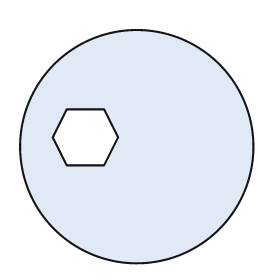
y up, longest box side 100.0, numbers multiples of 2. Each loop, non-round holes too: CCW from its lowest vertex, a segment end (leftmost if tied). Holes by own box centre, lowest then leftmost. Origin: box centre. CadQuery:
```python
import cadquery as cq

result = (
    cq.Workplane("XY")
    .moveTo(0.0, 0.0)
    .circle(50.0)
    .moveTo(-30.0, -8.0)
    .lineTo(-14.0, -8.0)
    .lineTo(-8.0, 4.0)
    .lineTo(-14.0, 16.0)
    .lineTo(-30.0, 16.0)
    .lineTo(-36.0, 4.0)
    .close()
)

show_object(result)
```